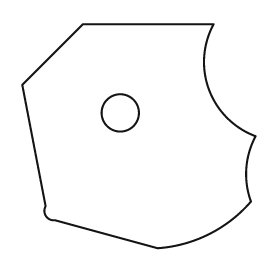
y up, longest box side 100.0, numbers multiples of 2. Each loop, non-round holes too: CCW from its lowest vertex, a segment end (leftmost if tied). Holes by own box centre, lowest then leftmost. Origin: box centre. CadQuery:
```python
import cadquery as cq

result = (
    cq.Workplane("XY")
    .moveTo(8.0, -48.0)
    .threePointArc((30.0, -42.0), (48.0, -28.0))
    .threePointArc((46.0, -14.0), (50.0, 0.0))
    .threePointArc((30.0, 20.0), (32.0, 48.0))
    .lineTo(-24.0, 48.0)
    .lineTo(-50.0, 22.0)
    .lineTo(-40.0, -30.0)
    .threePointArc((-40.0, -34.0), (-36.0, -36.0))
    .close()
    .moveTo(-8.0, 10.0)
    .circle(8.0)
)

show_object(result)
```